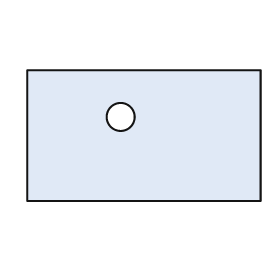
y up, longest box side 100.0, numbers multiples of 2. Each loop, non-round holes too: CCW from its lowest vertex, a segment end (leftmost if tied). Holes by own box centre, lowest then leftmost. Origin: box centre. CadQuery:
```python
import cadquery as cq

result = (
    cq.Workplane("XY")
    .moveTo(-50.0, -28.0)
    .lineTo(50.0, -28.0)
    .lineTo(50.0, 28.0)
    .lineTo(-50.0, 28.0)
    .close()
    .moveTo(-10.0, 8.0)
    .circle(6.0)
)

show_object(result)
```